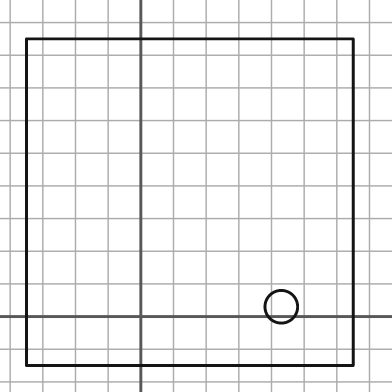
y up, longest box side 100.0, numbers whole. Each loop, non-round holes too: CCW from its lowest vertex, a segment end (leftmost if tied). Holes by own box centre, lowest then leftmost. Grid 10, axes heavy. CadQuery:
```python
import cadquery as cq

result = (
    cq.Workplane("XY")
    .moveTo(-35.0, -15.0)
    .lineTo(65.0, -15.0)
    .lineTo(65.0, 85.0)
    .lineTo(-35.0, 85.0)
    .close()
    .moveTo(43.0, 3.0)
    .circle(5.0)
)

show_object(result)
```